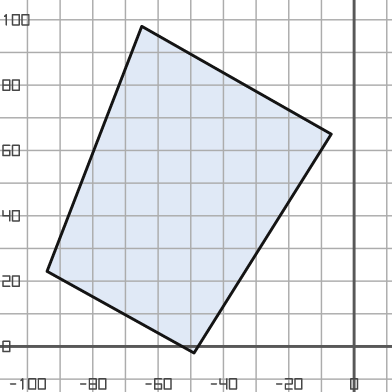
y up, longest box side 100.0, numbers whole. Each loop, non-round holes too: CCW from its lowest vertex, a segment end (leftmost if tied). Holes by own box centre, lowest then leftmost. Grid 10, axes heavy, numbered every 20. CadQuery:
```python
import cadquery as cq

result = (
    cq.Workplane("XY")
    .moveTo(-49.0, -2.0)
    .lineTo(-7.0, 65.0)
    .lineTo(-65.0, 98.0)
    .lineTo(-94.0, 23.0)
    .close()
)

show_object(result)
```